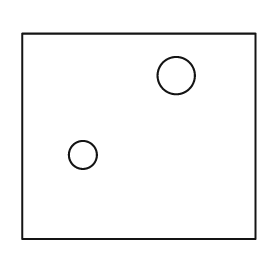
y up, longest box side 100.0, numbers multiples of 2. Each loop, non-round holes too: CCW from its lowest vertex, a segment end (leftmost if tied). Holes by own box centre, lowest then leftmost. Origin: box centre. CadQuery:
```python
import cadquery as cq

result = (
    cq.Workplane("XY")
    .moveTo(-50.0, -44.0)
    .lineTo(50.0, -44.0)
    .lineTo(50.0, 44.0)
    .lineTo(-50.0, 44.0)
    .close()
    .moveTo(-24.0, -8.0)
    .circle(6.0)
    .moveTo(16.0, 26.0)
    .circle(8.0)
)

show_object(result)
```